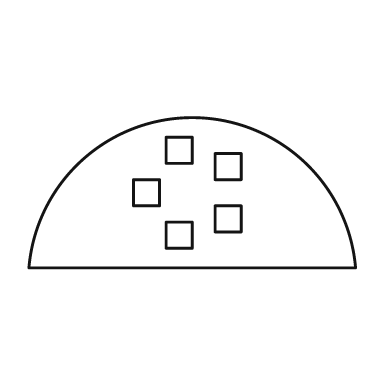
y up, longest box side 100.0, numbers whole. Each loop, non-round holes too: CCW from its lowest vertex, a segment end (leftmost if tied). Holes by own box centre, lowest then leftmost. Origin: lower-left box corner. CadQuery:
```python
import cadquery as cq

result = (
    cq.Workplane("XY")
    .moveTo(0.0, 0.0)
    .lineTo(100.0, 0.0)
    .threePointArc((50.0, 46.0), (0.0, 0.0))
    .close()
    .moveTo(42.0, 6.0)
    .lineTo(50.0, 6.0)
    .lineTo(50.0, 14.0)
    .lineTo(42.0, 14.0)
    .close()
    .moveTo(57.0, 11.0)
    .lineTo(65.0, 11.0)
    .lineTo(65.0, 19.0)
    .lineTo(57.0, 19.0)
    .close()
    .moveTo(32.0, 19.0)
    .lineTo(40.0, 19.0)
    .lineTo(40.0, 27.0)
    .lineTo(32.0, 27.0)
    .close()
    .moveTo(57.0, 27.0)
    .lineTo(65.0, 27.0)
    .lineTo(65.0, 35.0)
    .lineTo(57.0, 35.0)
    .close()
    .moveTo(42.0, 32.0)
    .lineTo(50.0, 32.0)
    .lineTo(50.0, 40.0)
    .lineTo(42.0, 40.0)
    .close()
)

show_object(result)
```